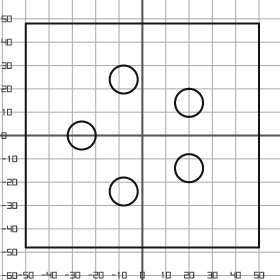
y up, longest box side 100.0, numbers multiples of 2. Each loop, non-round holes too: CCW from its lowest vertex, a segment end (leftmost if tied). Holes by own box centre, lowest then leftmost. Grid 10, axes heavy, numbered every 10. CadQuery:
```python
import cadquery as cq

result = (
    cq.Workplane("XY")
    .moveTo(-50.0, -48.0)
    .lineTo(50.0, -48.0)
    .lineTo(50.0, 48.0)
    .lineTo(-50.0, 48.0)
    .close()
    .moveTo(-8.0, -24.0)
    .circle(6.0)
    .moveTo(20.0, -14.0)
    .circle(6.0)
    .moveTo(-26.0, 0.0)
    .circle(6.0)
    .moveTo(20.0, 14.0)
    .circle(6.0)
    .moveTo(-8.0, 24.0)
    .circle(6.0)
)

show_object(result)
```